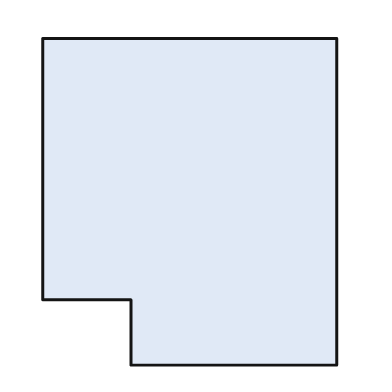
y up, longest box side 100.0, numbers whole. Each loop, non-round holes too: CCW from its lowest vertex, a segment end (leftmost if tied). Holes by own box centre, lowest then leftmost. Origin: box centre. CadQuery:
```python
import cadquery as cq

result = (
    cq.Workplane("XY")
    .moveTo(-18.0, -50.0)
    .lineTo(45.0, -50.0)
    .lineTo(45.0, 50.0)
    .lineTo(-45.0, 50.0)
    .lineTo(-45.0, -30.0)
    .lineTo(-18.0, -30.0)
    .close()
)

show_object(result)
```